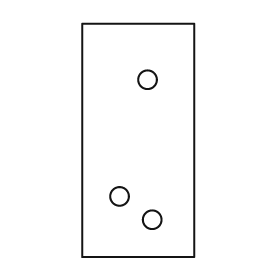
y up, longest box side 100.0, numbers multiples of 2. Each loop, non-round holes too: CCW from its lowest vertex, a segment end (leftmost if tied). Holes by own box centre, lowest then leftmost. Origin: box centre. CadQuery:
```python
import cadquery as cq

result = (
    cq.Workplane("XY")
    .moveTo(-24.0, -50.0)
    .lineTo(24.0, -50.0)
    .lineTo(24.0, 50.0)
    .lineTo(-24.0, 50.0)
    .close()
    .moveTo(6.0, -34.0)
    .circle(4.0)
    .moveTo(-8.0, -24.0)
    .circle(4.0)
    .moveTo(4.0, 26.0)
    .circle(4.0)
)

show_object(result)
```